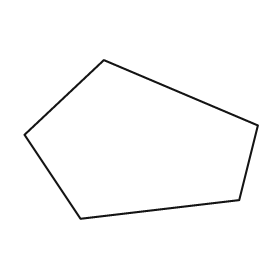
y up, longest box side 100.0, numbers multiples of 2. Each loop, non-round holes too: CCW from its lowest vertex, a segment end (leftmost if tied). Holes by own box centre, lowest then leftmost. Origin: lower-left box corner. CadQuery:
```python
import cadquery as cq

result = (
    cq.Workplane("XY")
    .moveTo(24.0, 0.0)
    .lineTo(92.0, 8.0)
    .lineTo(100.0, 40.0)
    .lineTo(34.0, 68.0)
    .lineTo(0.0, 36.0)
    .close()
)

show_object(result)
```